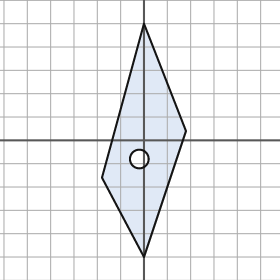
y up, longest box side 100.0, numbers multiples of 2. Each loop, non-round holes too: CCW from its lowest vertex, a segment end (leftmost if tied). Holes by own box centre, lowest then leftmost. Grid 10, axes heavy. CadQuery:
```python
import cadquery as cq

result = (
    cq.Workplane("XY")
    .moveTo(0.0, -50.0)
    .lineTo(18.0, 4.0)
    .lineTo(0.0, 50.0)
    .lineTo(-18.0, -16.0)
    .close()
    .moveTo(-2.0, -8.0)
    .circle(4.0)
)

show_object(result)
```